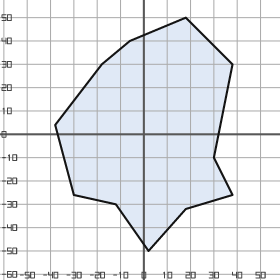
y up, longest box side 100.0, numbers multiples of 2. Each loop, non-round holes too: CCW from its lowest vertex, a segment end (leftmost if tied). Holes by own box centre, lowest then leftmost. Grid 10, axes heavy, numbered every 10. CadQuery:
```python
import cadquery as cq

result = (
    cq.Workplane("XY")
    .moveTo(2.0, -50.0)
    .lineTo(18.0, -32.0)
    .lineTo(38.0, -26.0)
    .lineTo(30.0, -10.0)
    .lineTo(38.0, 30.0)
    .lineTo(18.0, 50.0)
    .lineTo(-6.0, 40.0)
    .lineTo(-18.0, 30.0)
    .lineTo(-38.0, 4.0)
    .lineTo(-30.0, -26.0)
    .lineTo(-12.0, -30.0)
    .close()
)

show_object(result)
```